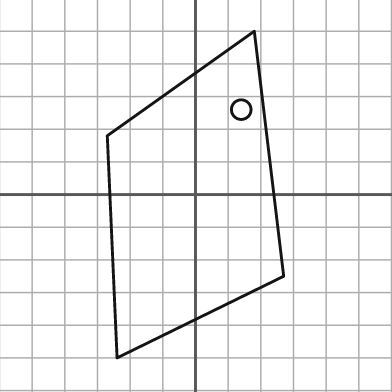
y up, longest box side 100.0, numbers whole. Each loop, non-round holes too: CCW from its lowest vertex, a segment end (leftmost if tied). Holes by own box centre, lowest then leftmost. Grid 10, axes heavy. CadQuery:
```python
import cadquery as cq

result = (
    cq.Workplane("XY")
    .moveTo(-24.0, -50.0)
    .lineTo(27.0, -25.0)
    .lineTo(18.0, 50.0)
    .lineTo(-27.0, 18.0)
    .close()
    .moveTo(14.0, 26.0)
    .circle(3.0)
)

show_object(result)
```